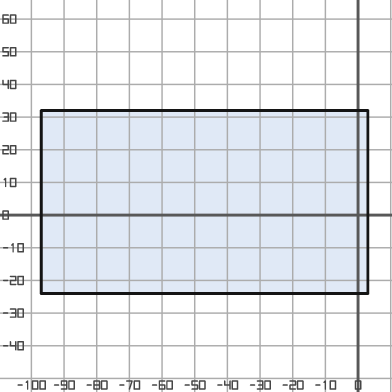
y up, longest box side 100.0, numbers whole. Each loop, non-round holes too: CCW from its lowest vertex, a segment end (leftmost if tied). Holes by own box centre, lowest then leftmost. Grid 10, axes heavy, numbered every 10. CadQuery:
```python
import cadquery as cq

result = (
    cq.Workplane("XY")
    .moveTo(-97.0, -24.0)
    .lineTo(3.0, -24.0)
    .lineTo(3.0, 32.0)
    .lineTo(-97.0, 32.0)
    .close()
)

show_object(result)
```